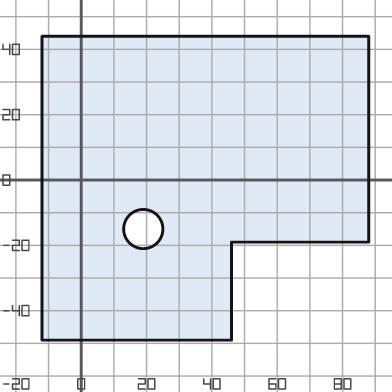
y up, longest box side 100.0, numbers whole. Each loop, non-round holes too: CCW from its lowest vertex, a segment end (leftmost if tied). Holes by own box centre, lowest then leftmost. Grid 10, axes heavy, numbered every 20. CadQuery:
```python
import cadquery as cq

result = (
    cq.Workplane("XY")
    .moveTo(-12.0, -49.0)
    .lineTo(46.0, -49.0)
    .lineTo(46.0, -19.0)
    .lineTo(88.0, -19.0)
    .lineTo(88.0, 44.0)
    .lineTo(-12.0, 44.0)
    .close()
    .moveTo(19.0, -15.0)
    .circle(6.0)
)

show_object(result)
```